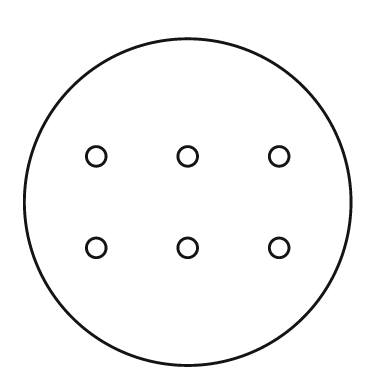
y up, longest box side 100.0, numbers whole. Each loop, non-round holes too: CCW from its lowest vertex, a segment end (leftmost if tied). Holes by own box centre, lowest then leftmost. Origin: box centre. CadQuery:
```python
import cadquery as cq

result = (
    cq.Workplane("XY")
    .moveTo(0.0, 0.0)
    .circle(50.0)
    .moveTo(-28.0, -14.0)
    .circle(3.0)
    .moveTo(0.0, -14.0)
    .circle(3.0)
    .moveTo(28.0, -14.0)
    .circle(3.0)
    .moveTo(-28.0, 14.0)
    .circle(3.0)
    .moveTo(0.0, 14.0)
    .circle(3.0)
    .moveTo(28.0, 14.0)
    .circle(3.0)
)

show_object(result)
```